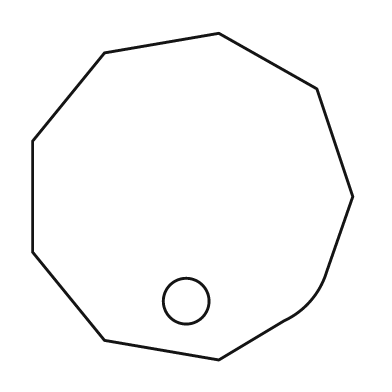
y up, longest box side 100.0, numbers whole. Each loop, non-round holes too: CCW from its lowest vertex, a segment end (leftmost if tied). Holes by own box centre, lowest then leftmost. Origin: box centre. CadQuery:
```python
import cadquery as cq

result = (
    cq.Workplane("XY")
    .moveTo(8.0, -50.0)
    .lineTo(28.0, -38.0)
    .threePointArc((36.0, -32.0), (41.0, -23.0))
    .lineTo(49.0, 0.0)
    .lineTo(38.0, 33.0)
    .lineTo(8.0, 50.0)
    .lineTo(-27.0, 44.0)
    .lineTo(-49.0, 17.0)
    .lineTo(-49.0, -17.0)
    .lineTo(-27.0, -44.0)
    .close()
    .moveTo(-2.0, -32.0)
    .circle(7.0)
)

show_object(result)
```